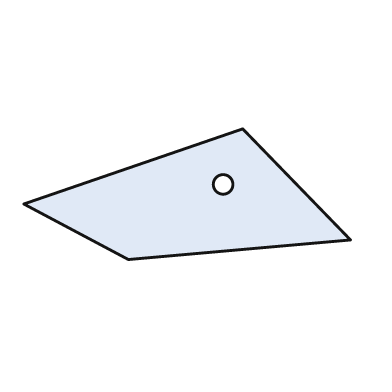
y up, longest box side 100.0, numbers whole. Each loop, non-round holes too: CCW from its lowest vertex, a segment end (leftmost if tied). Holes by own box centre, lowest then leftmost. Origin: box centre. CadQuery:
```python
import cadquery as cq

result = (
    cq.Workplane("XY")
    .moveTo(-18.0, -20.0)
    .lineTo(50.0, -14.0)
    .lineTo(17.0, 20.0)
    .lineTo(-50.0, -3.0)
    .close()
    .moveTo(11.0, 3.0)
    .circle(3.0)
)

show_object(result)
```